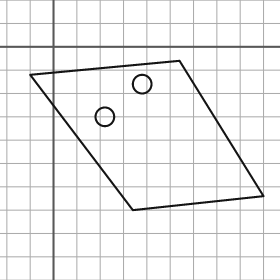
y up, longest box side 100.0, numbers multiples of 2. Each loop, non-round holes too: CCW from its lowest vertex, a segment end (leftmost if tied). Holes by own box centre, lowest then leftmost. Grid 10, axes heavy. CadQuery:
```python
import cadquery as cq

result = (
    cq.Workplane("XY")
    .moveTo(34.0, -70.0)
    .lineTo(90.0, -64.0)
    .lineTo(54.0, -6.0)
    .lineTo(-10.0, -12.0)
    .close()
    .moveTo(22.0, -30.0)
    .circle(4.0)
    .moveTo(38.0, -16.0)
    .circle(4.0)
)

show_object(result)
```